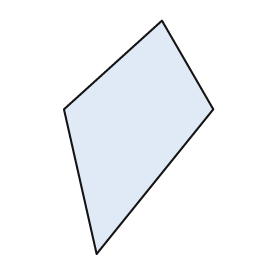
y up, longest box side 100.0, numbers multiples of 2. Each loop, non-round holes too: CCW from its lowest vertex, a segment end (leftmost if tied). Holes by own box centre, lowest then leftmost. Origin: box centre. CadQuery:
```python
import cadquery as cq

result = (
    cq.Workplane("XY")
    .moveTo(-18.0, -50.0)
    .lineTo(32.0, 12.0)
    .lineTo(10.0, 50.0)
    .lineTo(-32.0, 12.0)
    .close()
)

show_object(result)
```